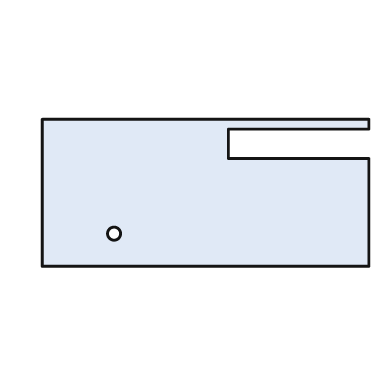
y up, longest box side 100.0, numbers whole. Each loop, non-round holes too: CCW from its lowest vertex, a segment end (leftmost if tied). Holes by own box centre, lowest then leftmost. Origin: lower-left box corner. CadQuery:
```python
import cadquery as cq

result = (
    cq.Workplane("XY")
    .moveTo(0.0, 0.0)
    .lineTo(100.0, 0.0)
    .lineTo(100.0, 33.0)
    .lineTo(57.0, 33.0)
    .lineTo(57.0, 42.0)
    .lineTo(100.0, 42.0)
    .lineTo(100.0, 45.0)
    .lineTo(0.0, 45.0)
    .close()
    .moveTo(22.0, 10.0)
    .circle(2.0)
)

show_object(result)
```